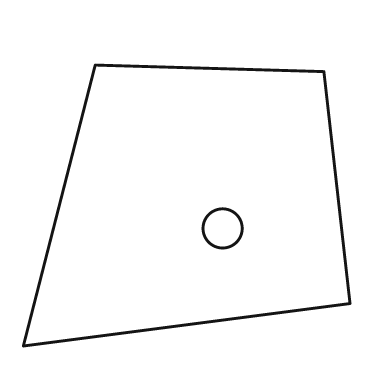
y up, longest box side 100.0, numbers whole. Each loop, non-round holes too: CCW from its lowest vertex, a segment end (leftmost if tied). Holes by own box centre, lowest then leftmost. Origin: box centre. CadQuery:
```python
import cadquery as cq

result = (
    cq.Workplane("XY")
    .moveTo(-50.0, -43.0)
    .lineTo(50.0, -30.0)
    .lineTo(42.0, 41.0)
    .lineTo(-28.0, 43.0)
    .close()
    .moveTo(11.0, -7.0)
    .circle(6.0)
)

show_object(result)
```